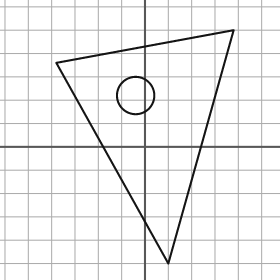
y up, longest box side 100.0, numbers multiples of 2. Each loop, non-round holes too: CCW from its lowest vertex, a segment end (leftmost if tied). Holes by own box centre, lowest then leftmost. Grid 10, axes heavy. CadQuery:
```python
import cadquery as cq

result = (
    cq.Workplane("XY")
    .moveTo(10.0, -50.0)
    .lineTo(38.0, 50.0)
    .lineTo(-38.0, 36.0)
    .close()
    .moveTo(-4.0, 22.0)
    .circle(8.0)
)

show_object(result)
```